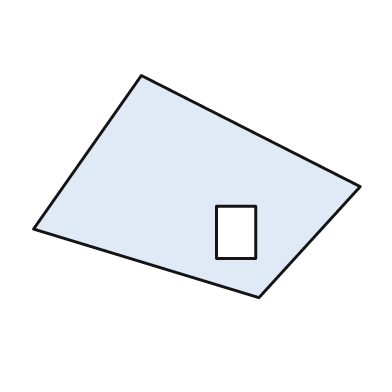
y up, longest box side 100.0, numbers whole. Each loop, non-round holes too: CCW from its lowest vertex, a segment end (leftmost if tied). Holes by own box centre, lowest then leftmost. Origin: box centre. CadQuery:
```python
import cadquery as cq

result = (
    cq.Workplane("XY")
    .moveTo(19.0, -34.0)
    .lineTo(50.0, 0.0)
    .lineTo(-17.0, 34.0)
    .lineTo(-50.0, -13.0)
    .close()
    .moveTo(6.0, -22.0)
    .lineTo(18.0, -22.0)
    .lineTo(18.0, -6.0)
    .lineTo(6.0, -6.0)
    .close()
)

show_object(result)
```